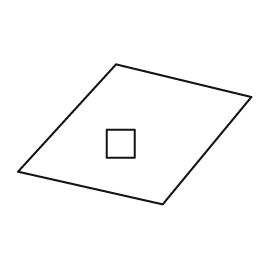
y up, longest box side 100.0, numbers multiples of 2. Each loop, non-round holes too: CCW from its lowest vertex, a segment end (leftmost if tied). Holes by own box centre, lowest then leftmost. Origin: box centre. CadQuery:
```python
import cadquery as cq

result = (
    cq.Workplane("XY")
    .moveTo(12.0, -30.0)
    .lineTo(50.0, 16.0)
    .lineTo(-8.0, 30.0)
    .lineTo(-50.0, -16.0)
    .close()
    .moveTo(-12.0, -10.0)
    .lineTo(0.0, -10.0)
    .lineTo(0.0, 2.0)
    .lineTo(-12.0, 2.0)
    .close()
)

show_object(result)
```